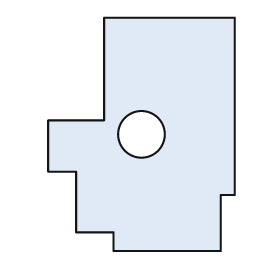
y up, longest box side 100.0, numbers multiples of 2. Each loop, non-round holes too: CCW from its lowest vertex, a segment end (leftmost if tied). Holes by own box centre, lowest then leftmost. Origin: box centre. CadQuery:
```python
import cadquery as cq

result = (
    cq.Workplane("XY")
    .moveTo(-12.0, -50.0)
    .lineTo(34.0, -50.0)
    .lineTo(34.0, -26.0)
    .lineTo(40.0, -26.0)
    .lineTo(40.0, 50.0)
    .lineTo(-16.0, 50.0)
    .lineTo(-16.0, 6.0)
    .lineTo(-40.0, 6.0)
    .lineTo(-40.0, -16.0)
    .lineTo(-28.0, -16.0)
    .lineTo(-28.0, -42.0)
    .lineTo(-12.0, -42.0)
    .close()
    .moveTo(0.0, 0.0)
    .circle(10.0)
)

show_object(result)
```